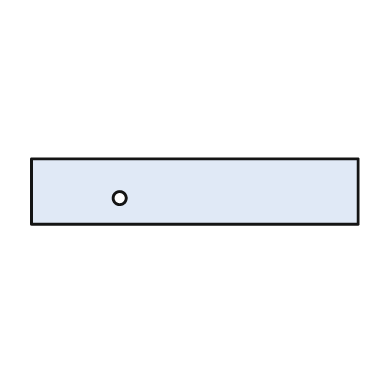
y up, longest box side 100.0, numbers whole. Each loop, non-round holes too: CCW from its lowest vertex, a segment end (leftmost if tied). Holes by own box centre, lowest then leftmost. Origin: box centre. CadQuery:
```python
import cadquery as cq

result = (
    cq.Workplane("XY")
    .moveTo(-50.0, -10.0)
    .lineTo(50.0, -10.0)
    .lineTo(50.0, 10.0)
    .lineTo(-50.0, 10.0)
    .close()
    .moveTo(-23.0, -2.0)
    .circle(2.0)
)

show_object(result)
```